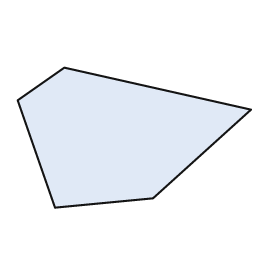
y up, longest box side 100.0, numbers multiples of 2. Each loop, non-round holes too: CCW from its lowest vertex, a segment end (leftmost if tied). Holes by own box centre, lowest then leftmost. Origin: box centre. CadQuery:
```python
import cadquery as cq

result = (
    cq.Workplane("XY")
    .moveTo(-34.0, -30.0)
    .lineTo(8.0, -26.0)
    .lineTo(50.0, 12.0)
    .lineTo(-30.0, 30.0)
    .lineTo(-50.0, 16.0)
    .close()
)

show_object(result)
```